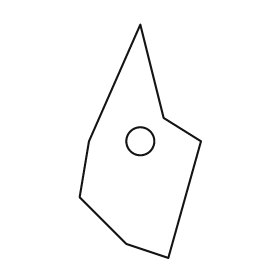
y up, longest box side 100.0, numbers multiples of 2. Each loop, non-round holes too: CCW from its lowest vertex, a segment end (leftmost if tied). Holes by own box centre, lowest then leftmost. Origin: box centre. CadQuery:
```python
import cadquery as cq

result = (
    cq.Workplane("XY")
    .moveTo(12.0, -50.0)
    .lineTo(26.0, 0.0)
    .lineTo(10.0, 10.0)
    .lineTo(0.0, 50.0)
    .lineTo(-22.0, 0.0)
    .lineTo(-26.0, -24.0)
    .lineTo(-6.0, -44.0)
    .close()
    .moveTo(0.0, 0.0)
    .circle(6.0)
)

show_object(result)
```